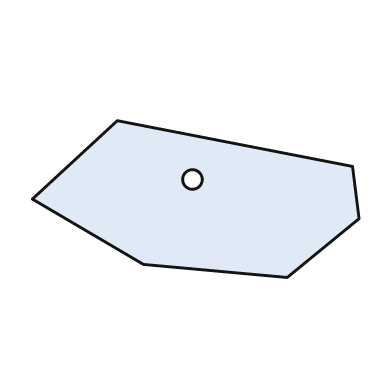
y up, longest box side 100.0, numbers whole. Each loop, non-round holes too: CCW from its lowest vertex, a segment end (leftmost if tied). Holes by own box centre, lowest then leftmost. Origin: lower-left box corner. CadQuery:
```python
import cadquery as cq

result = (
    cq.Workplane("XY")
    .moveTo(78.0, 0.0)
    .lineTo(100.0, 18.0)
    .lineTo(98.0, 34.0)
    .lineTo(26.0, 48.0)
    .lineTo(0.0, 24.0)
    .lineTo(34.0, 4.0)
    .close()
    .moveTo(49.0, 30.0)
    .circle(3.0)
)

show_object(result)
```